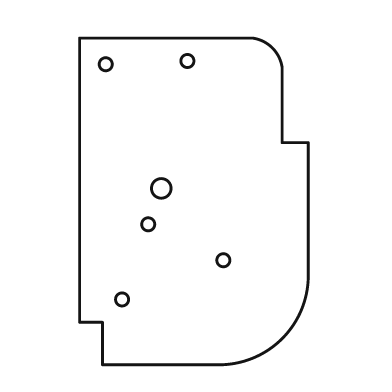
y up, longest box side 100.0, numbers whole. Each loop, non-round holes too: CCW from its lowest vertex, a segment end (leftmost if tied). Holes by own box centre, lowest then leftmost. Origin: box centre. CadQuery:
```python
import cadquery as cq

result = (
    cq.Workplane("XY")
    .moveTo(-28.0, -50.0)
    .lineTo(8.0, -50.0)
    .threePointArc((27.0, -42.0), (35.0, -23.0))
    .lineTo(35.0, 18.0)
    .lineTo(27.0, 18.0)
    .lineTo(27.0, 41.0)
    .threePointArc((24.0, 47.0), (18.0, 50.0))
    .lineTo(-35.0, 50.0)
    .lineTo(-35.0, -37.0)
    .lineTo(-28.0, -37.0)
    .close()
    .moveTo(-22.0, -30.0)
    .circle(2.0)
    .moveTo(9.0, -18.0)
    .circle(2.0)
    .moveTo(-14.0, -7.0)
    .circle(2.0)
    .moveTo(-10.0, 4.0)
    .circle(3.0)
    .moveTo(-27.0, 42.0)
    .circle(2.0)
    .moveTo(-2.0, 43.0)
    .circle(2.0)
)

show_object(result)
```